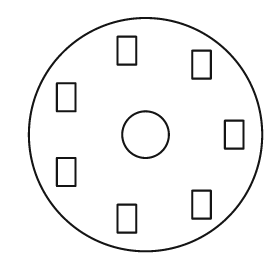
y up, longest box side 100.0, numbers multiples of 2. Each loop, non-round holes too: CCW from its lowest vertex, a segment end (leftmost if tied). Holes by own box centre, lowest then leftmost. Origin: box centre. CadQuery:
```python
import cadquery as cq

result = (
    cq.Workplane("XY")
    .moveTo(0.0, 0.0)
    .circle(50.0)
    .moveTo(-12.0, -42.0)
    .lineTo(-4.0, -42.0)
    .lineTo(-4.0, -30.0)
    .lineTo(-12.0, -30.0)
    .close()
    .moveTo(20.0, -36.0)
    .lineTo(28.0, -36.0)
    .lineTo(28.0, -24.0)
    .lineTo(20.0, -24.0)
    .close()
    .moveTo(-38.0, -22.0)
    .lineTo(-30.0, -22.0)
    .lineTo(-30.0, -10.0)
    .lineTo(-38.0, -10.0)
    .close()
    .moveTo(0.0, 0.0)
    .circle(10.0)
    .moveTo(34.0, -6.0)
    .lineTo(42.0, -6.0)
    .lineTo(42.0, 6.0)
    .lineTo(34.0, 6.0)
    .close()
    .moveTo(-38.0, 10.0)
    .lineTo(-30.0, 10.0)
    .lineTo(-30.0, 22.0)
    .lineTo(-38.0, 22.0)
    .close()
    .moveTo(20.0, 24.0)
    .lineTo(28.0, 24.0)
    .lineTo(28.0, 36.0)
    .lineTo(20.0, 36.0)
    .close()
    .moveTo(-12.0, 30.0)
    .lineTo(-4.0, 30.0)
    .lineTo(-4.0, 42.0)
    .lineTo(-12.0, 42.0)
    .close()
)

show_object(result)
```